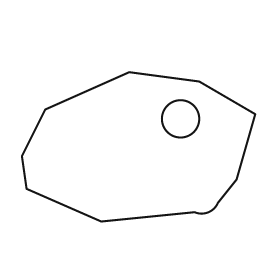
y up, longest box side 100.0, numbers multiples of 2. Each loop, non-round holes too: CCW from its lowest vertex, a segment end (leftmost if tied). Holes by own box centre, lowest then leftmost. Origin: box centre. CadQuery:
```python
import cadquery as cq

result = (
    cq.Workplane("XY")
    .moveTo(-16.0, -32.0)
    .lineTo(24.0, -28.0)
    .threePointArc((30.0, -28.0), (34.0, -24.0))
    .lineTo(42.0, -14.0)
    .lineTo(50.0, 14.0)
    .lineTo(26.0, 28.0)
    .lineTo(-4.0, 32.0)
    .lineTo(-40.0, 16.0)
    .lineTo(-50.0, -4.0)
    .lineTo(-48.0, -18.0)
    .close()
    .moveTo(18.0, 12.0)
    .circle(8.0)
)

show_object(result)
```